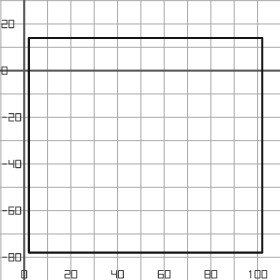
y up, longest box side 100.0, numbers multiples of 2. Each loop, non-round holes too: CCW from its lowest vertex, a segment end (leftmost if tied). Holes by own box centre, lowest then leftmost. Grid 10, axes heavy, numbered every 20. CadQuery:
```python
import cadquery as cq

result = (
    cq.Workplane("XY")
    .moveTo(2.0, -78.0)
    .lineTo(102.0, -78.0)
    .lineTo(102.0, 14.0)
    .lineTo(2.0, 14.0)
    .close()
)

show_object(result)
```